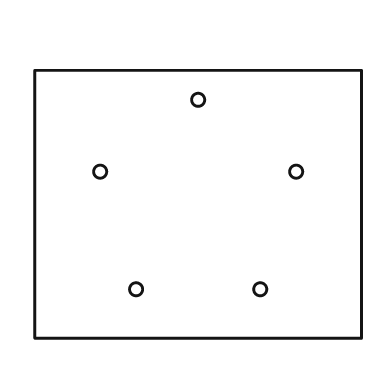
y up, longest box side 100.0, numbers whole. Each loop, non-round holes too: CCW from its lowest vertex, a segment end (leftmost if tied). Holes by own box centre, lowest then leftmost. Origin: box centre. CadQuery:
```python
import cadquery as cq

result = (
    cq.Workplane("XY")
    .moveTo(-50.0, -41.0)
    .lineTo(50.0, -41.0)
    .lineTo(50.0, 41.0)
    .lineTo(-50.0, 41.0)
    .close()
    .moveTo(-19.0, -26.0)
    .circle(2.0)
    .moveTo(19.0, -26.0)
    .circle(2.0)
    .moveTo(-30.0, 10.0)
    .circle(2.0)
    .moveTo(30.0, 10.0)
    .circle(2.0)
    .moveTo(0.0, 32.0)
    .circle(2.0)
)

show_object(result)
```